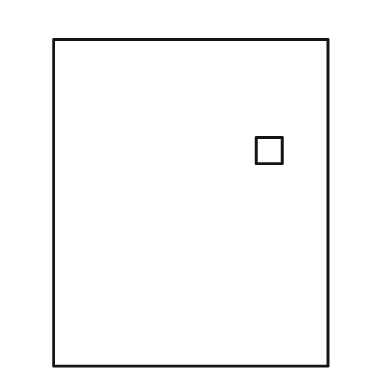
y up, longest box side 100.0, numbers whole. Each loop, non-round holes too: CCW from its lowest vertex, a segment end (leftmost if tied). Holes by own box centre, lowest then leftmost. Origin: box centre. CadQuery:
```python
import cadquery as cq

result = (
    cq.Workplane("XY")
    .moveTo(-42.0, -50.0)
    .lineTo(42.0, -50.0)
    .lineTo(42.0, 50.0)
    .lineTo(-42.0, 50.0)
    .close()
    .moveTo(20.0, 12.0)
    .lineTo(28.0, 12.0)
    .lineTo(28.0, 20.0)
    .lineTo(20.0, 20.0)
    .close()
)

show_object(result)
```